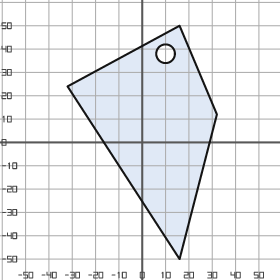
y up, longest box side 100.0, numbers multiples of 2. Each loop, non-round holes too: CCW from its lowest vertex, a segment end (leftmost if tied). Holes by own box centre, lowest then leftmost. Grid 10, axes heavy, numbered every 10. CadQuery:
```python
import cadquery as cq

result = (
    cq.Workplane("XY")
    .moveTo(16.0, -50.0)
    .lineTo(32.0, 12.0)
    .lineTo(16.0, 50.0)
    .lineTo(-32.0, 24.0)
    .close()
    .moveTo(10.0, 38.0)
    .circle(4.0)
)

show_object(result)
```